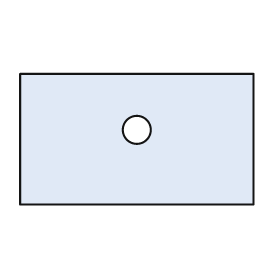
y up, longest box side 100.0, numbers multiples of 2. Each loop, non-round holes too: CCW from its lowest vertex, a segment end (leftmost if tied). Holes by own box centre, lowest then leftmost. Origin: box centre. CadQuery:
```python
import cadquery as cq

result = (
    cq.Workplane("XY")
    .moveTo(-50.0, -28.0)
    .lineTo(50.0, -28.0)
    .lineTo(50.0, 28.0)
    .lineTo(-50.0, 28.0)
    .close()
    .moveTo(0.0, 4.0)
    .circle(6.0)
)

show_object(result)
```